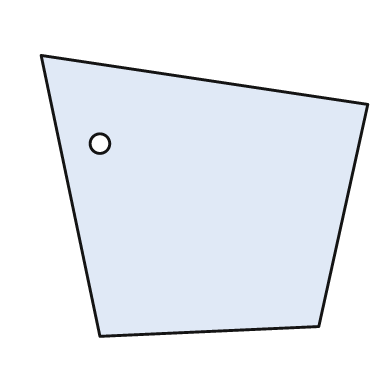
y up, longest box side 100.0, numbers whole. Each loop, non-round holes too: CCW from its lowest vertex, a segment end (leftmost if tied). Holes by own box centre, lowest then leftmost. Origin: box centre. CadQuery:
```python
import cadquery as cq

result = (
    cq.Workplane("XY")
    .moveTo(-32.0, -43.0)
    .lineTo(35.0, -40.0)
    .lineTo(50.0, 28.0)
    .lineTo(-50.0, 43.0)
    .close()
    .moveTo(-32.0, 16.0)
    .circle(3.0)
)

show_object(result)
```